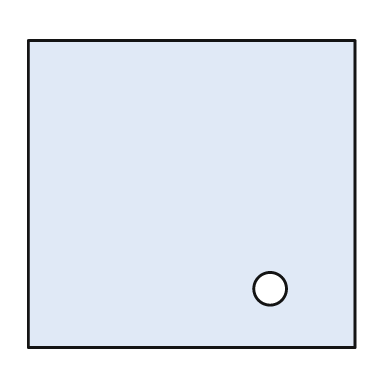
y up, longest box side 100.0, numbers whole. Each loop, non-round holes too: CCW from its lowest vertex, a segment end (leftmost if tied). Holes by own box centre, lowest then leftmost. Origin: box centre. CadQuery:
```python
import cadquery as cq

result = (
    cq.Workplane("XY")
    .moveTo(-50.0, -47.0)
    .lineTo(50.0, -47.0)
    .lineTo(50.0, 47.0)
    .lineTo(-50.0, 47.0)
    .close()
    .moveTo(24.0, -29.0)
    .circle(5.0)
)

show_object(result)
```